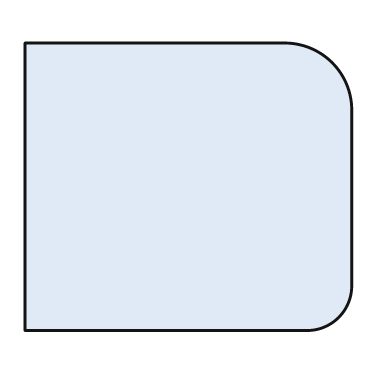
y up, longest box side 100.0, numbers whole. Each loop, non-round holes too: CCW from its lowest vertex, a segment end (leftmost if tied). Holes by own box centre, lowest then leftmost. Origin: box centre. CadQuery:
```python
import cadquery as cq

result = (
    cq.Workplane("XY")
    .moveTo(-50.0, -44.0)
    .lineTo(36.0, -44.0)
    .threePointArc((46.0, -40.0), (50.0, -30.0))
    .lineTo(50.0, 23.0)
    .threePointArc((44.0, 38.0), (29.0, 44.0))
    .lineTo(-50.0, 44.0)
    .close()
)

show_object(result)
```